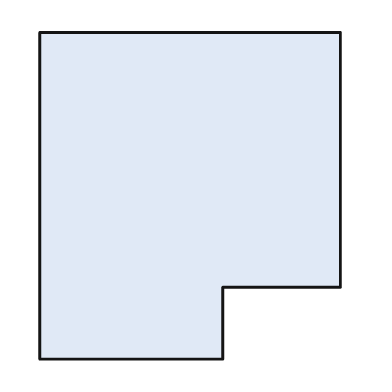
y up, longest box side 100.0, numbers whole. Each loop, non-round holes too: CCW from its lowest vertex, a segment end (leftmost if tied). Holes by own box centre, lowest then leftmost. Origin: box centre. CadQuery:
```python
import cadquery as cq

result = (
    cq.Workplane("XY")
    .moveTo(-46.0, -50.0)
    .lineTo(10.0, -50.0)
    .lineTo(10.0, -28.0)
    .lineTo(46.0, -28.0)
    .lineTo(46.0, 50.0)
    .lineTo(-46.0, 50.0)
    .close()
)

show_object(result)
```